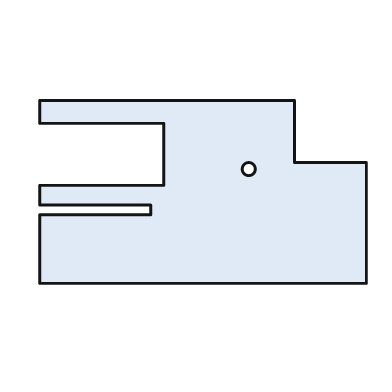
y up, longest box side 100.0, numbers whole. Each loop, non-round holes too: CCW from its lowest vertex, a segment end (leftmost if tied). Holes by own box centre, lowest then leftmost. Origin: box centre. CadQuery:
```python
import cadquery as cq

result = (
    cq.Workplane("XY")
    .moveTo(-50.0, -28.0)
    .lineTo(50.0, -28.0)
    .lineTo(50.0, 9.0)
    .lineTo(28.0, 9.0)
    .lineTo(28.0, 28.0)
    .lineTo(-50.0, 28.0)
    .lineTo(-50.0, 21.0)
    .lineTo(-12.0, 21.0)
    .lineTo(-12.0, 2.0)
    .lineTo(-50.0, 2.0)
    .lineTo(-50.0, -4.0)
    .lineTo(-16.0, -4.0)
    .lineTo(-16.0, -7.0)
    .lineTo(-50.0, -7.0)
    .close()
    .moveTo(14.0, 7.0)
    .circle(2.0)
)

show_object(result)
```